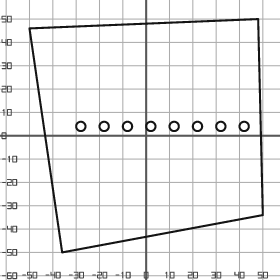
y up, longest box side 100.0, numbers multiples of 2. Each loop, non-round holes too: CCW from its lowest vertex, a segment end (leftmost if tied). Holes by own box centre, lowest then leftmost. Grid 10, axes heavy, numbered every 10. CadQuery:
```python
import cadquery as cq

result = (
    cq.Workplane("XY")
    .moveTo(-36.0, -50.0)
    .lineTo(50.0, -34.0)
    .lineTo(48.0, 50.0)
    .lineTo(-50.0, 46.0)
    .close()
    .moveTo(-28.0, 4.0)
    .circle(2.0)
    .moveTo(-18.0, 4.0)
    .circle(2.0)
    .moveTo(-8.0, 4.0)
    .circle(2.0)
    .moveTo(2.0, 4.0)
    .circle(2.0)
    .moveTo(12.0, 4.0)
    .circle(2.0)
    .moveTo(22.0, 4.0)
    .circle(2.0)
    .moveTo(32.0, 4.0)
    .circle(2.0)
    .moveTo(42.0, 4.0)
    .circle(2.0)
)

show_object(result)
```